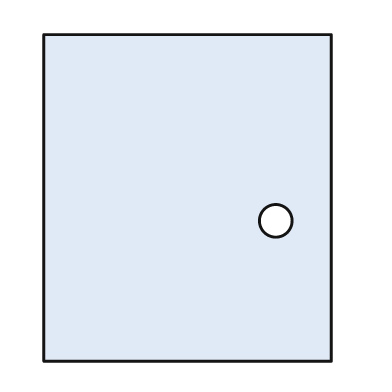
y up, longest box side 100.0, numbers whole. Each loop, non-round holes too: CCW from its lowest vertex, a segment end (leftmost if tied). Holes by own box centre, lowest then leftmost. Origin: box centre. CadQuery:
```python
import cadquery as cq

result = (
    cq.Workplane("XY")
    .moveTo(-44.0, -50.0)
    .lineTo(44.0, -50.0)
    .lineTo(44.0, 50.0)
    .lineTo(-44.0, 50.0)
    .close()
    .moveTo(27.0, -7.0)
    .circle(5.0)
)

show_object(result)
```